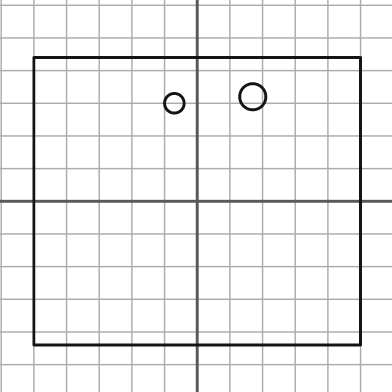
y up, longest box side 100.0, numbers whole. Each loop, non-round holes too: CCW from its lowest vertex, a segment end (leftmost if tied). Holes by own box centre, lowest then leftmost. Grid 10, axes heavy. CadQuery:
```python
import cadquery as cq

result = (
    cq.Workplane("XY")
    .moveTo(-50.0, -44.0)
    .lineTo(50.0, -44.0)
    .lineTo(50.0, 44.0)
    .lineTo(-50.0, 44.0)
    .close()
    .moveTo(-7.0, 30.0)
    .circle(3.0)
    .moveTo(17.0, 32.0)
    .circle(4.0)
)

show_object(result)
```